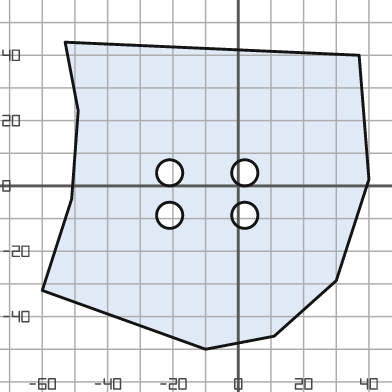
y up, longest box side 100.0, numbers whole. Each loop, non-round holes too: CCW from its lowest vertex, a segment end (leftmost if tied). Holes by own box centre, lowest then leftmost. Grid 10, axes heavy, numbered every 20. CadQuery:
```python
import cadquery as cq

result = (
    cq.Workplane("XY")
    .moveTo(-10.0, -50.0)
    .lineTo(11.0, -46.0)
    .lineTo(30.0, -29.0)
    .lineTo(40.0, 2.0)
    .lineTo(37.0, 40.0)
    .lineTo(-53.0, 44.0)
    .lineTo(-49.0, 23.0)
    .lineTo(-51.0, -4.0)
    .lineTo(-60.0, -32.0)
    .close()
    .moveTo(-21.0, -9.0)
    .circle(4.0)
    .moveTo(2.0, -9.0)
    .circle(4.0)
    .moveTo(-21.0, 4.0)
    .circle(4.0)
    .moveTo(2.0, 4.0)
    .circle(4.0)
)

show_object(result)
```